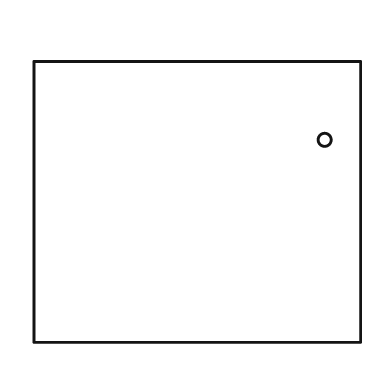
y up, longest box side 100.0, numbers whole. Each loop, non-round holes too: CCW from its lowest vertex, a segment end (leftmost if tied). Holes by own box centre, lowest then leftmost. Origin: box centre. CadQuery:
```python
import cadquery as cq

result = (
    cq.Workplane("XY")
    .moveTo(-50.0, -43.0)
    .lineTo(50.0, -43.0)
    .lineTo(50.0, 43.0)
    .lineTo(-50.0, 43.0)
    .close()
    .moveTo(39.0, 19.0)
    .circle(2.0)
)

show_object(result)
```